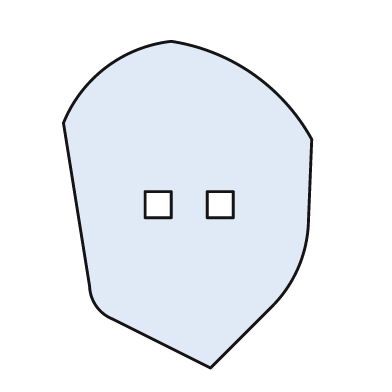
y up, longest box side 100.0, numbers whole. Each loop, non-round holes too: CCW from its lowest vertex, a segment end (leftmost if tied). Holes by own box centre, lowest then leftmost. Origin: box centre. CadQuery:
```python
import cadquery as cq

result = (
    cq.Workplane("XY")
    .moveTo(7.0, -50.0)
    .lineTo(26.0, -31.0)
    .threePointArc((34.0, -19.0), (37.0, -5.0))
    .lineTo(38.0, 20.0)
    .threePointArc((20.0, 40.0), (-5.0, 50.0))
    .threePointArc((-25.0, 42.0), (-38.0, 25.0))
    .lineTo(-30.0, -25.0)
    .threePointArc((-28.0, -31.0), (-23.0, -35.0))
    .close()
    .moveTo(-13.0, -4.0)
    .lineTo(-5.0, -4.0)
    .lineTo(-5.0, 4.0)
    .lineTo(-13.0, 4.0)
    .close()
    .moveTo(6.0, -4.0)
    .lineTo(14.0, -4.0)
    .lineTo(14.0, 4.0)
    .lineTo(6.0, 4.0)
    .close()
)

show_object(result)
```